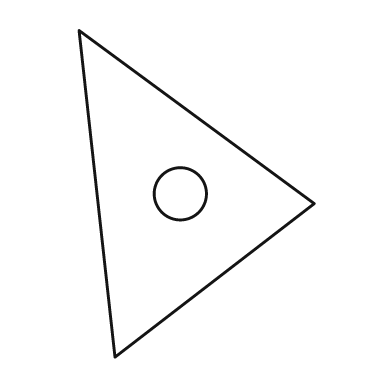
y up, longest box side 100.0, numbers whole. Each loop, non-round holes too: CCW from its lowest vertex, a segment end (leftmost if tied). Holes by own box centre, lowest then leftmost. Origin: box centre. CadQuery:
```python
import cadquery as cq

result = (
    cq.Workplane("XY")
    .moveTo(-25.0, -50.0)
    .lineTo(36.0, -3.0)
    .lineTo(-36.0, 50.0)
    .close()
    .moveTo(-5.0, 0.0)
    .circle(8.0)
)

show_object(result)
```